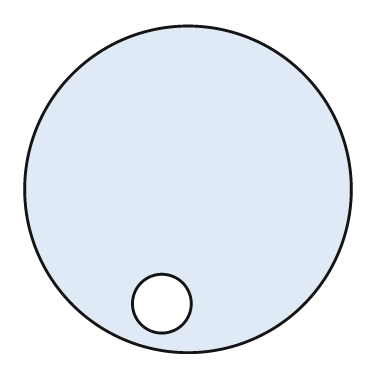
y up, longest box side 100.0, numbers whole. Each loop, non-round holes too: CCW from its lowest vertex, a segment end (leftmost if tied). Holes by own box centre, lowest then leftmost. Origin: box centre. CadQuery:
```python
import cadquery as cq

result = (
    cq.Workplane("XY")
    .moveTo(0.0, 0.0)
    .circle(50.0)
    .moveTo(-8.0, -35.0)
    .circle(9.0)
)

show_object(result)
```